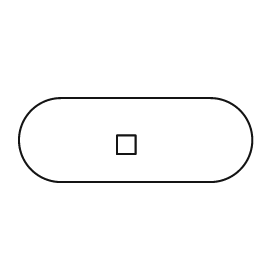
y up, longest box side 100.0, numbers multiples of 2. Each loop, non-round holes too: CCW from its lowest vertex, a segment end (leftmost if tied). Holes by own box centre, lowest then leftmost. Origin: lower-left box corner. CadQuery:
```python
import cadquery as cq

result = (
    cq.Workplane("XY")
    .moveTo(18.0, 0.0)
    .lineTo(82.0, 0.0)
    .threePointArc((100.0, 18.0), (82.0, 36.0))
    .lineTo(18.0, 36.0)
    .threePointArc((0.0, 18.0), (18.0, 0.0))
    .close()
    .moveTo(42.0, 12.0)
    .lineTo(50.0, 12.0)
    .lineTo(50.0, 20.0)
    .lineTo(42.0, 20.0)
    .close()
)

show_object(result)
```